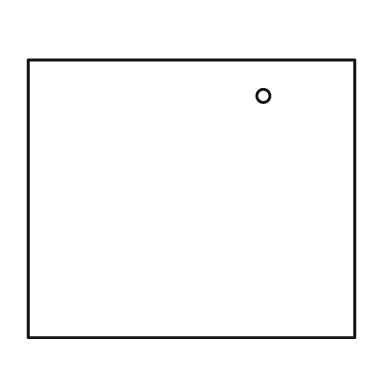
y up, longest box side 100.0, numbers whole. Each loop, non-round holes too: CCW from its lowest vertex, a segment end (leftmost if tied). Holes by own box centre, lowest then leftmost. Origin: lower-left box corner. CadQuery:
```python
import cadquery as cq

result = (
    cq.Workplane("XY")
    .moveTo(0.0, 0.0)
    .lineTo(100.0, 0.0)
    .lineTo(100.0, 85.0)
    .lineTo(0.0, 85.0)
    .close()
    .moveTo(72.0, 74.0)
    .circle(2.0)
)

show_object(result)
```